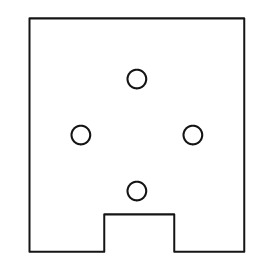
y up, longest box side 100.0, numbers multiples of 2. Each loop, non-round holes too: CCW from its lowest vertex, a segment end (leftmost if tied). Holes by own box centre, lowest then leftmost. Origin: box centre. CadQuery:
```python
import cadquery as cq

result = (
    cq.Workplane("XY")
    .moveTo(-46.0, -50.0)
    .lineTo(-14.0, -50.0)
    .lineTo(-14.0, -34.0)
    .lineTo(16.0, -34.0)
    .lineTo(16.0, -50.0)
    .lineTo(46.0, -50.0)
    .lineTo(46.0, 50.0)
    .lineTo(-46.0, 50.0)
    .close()
    .moveTo(0.0, -24.0)
    .circle(4.0)
    .moveTo(-24.0, 0.0)
    .circle(4.0)
    .moveTo(24.0, 0.0)
    .circle(4.0)
    .moveTo(0.0, 24.0)
    .circle(4.0)
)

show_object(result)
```